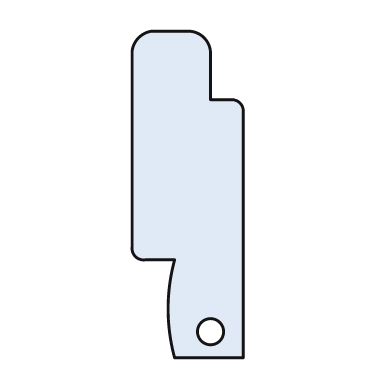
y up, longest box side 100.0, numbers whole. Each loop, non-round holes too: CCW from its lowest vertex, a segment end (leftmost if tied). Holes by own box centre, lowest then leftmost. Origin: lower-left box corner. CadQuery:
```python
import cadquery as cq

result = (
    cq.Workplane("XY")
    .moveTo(13.0, 0.0)
    .lineTo(34.0, 0.0)
    .lineTo(34.0, 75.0)
    .threePointArc((33.0, 78.0), (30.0, 79.0))
    .lineTo(24.0, 79.0)
    .lineTo(24.0, 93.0)
    .threePointArc((22.0, 98.0), (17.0, 100.0))
    .lineTo(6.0, 100.0)
    .threePointArc((2.0, 98.0), (0.0, 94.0))
    .lineTo(0.0, 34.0)
    .threePointArc((1.0, 31.0), (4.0, 30.0))
    .lineTo(13.0, 30.0)
    .threePointArc((11.0, 15.0), (13.0, 0.0))
    .close()
    .moveTo(24.0, 8.0)
    .circle(4.0)
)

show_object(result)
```